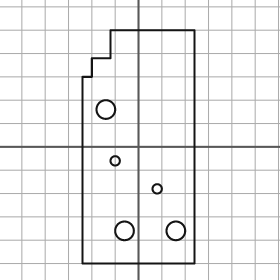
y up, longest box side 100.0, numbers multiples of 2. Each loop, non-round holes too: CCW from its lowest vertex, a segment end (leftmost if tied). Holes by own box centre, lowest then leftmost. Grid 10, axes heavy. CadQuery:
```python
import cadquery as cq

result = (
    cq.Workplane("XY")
    .moveTo(-24.0, -50.0)
    .lineTo(24.0, -50.0)
    .lineTo(24.0, 50.0)
    .lineTo(-12.0, 50.0)
    .lineTo(-12.0, 38.0)
    .lineTo(-20.0, 38.0)
    .lineTo(-20.0, 30.0)
    .lineTo(-24.0, 30.0)
    .close()
    .moveTo(-6.0, -36.0)
    .circle(4.0)
    .moveTo(16.0, -36.0)
    .circle(4.0)
    .moveTo(8.0, -18.0)
    .circle(2.0)
    .moveTo(-10.0, -6.0)
    .circle(2.0)
    .moveTo(-14.0, 16.0)
    .circle(4.0)
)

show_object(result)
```